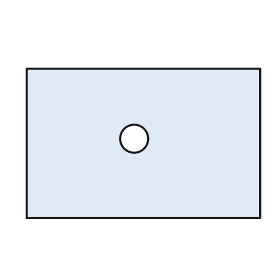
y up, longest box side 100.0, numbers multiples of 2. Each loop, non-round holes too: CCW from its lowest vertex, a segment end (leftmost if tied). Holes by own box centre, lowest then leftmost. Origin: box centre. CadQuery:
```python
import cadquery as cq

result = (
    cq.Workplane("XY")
    .moveTo(-50.0, -32.0)
    .lineTo(50.0, -32.0)
    .lineTo(50.0, 32.0)
    .lineTo(-50.0, 32.0)
    .close()
    .moveTo(-4.0, 2.0)
    .circle(6.0)
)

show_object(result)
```